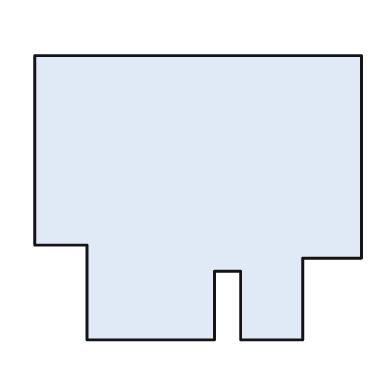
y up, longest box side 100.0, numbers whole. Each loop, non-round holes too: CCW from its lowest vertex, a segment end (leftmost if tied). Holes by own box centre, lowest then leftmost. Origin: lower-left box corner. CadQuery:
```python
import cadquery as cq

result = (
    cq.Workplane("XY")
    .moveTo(16.0, 0.0)
    .lineTo(55.0, 0.0)
    .lineTo(55.0, 21.0)
    .lineTo(63.0, 21.0)
    .lineTo(63.0, 0.0)
    .lineTo(82.0, 0.0)
    .lineTo(82.0, 25.0)
    .lineTo(100.0, 25.0)
    .lineTo(100.0, 87.0)
    .lineTo(0.0, 87.0)
    .lineTo(0.0, 29.0)
    .lineTo(16.0, 29.0)
    .close()
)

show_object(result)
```